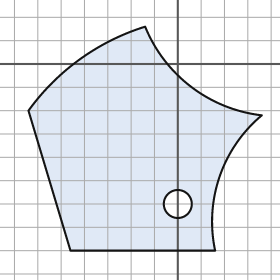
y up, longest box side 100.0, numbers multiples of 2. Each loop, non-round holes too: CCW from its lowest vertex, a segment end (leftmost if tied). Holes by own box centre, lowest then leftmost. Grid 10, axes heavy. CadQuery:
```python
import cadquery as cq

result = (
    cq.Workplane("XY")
    .moveTo(-46.0, -80.0)
    .lineTo(16.0, -80.0)
    .threePointArc((18.0, -48.0), (36.0, -22.0))
    .threePointArc((6.0, -10.0), (-14.0, 16.0))
    .threePointArc((-42.0, 2.0), (-64.0, -20.0))
    .close()
    .moveTo(0.0, -60.0)
    .circle(6.0)
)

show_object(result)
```